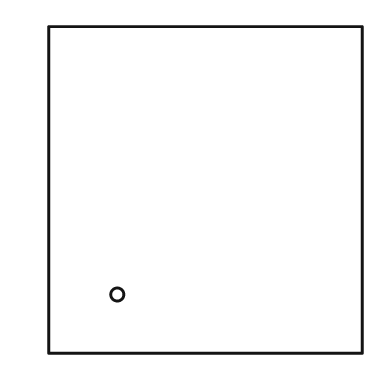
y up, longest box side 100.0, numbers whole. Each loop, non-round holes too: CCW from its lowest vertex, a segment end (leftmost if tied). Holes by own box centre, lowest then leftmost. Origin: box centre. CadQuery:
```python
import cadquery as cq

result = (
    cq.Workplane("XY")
    .moveTo(-48.0, -50.0)
    .lineTo(48.0, -50.0)
    .lineTo(48.0, 50.0)
    .lineTo(-48.0, 50.0)
    .close()
    .moveTo(-27.0, -32.0)
    .circle(2.0)
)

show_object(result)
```